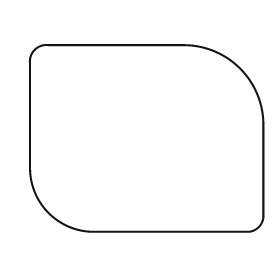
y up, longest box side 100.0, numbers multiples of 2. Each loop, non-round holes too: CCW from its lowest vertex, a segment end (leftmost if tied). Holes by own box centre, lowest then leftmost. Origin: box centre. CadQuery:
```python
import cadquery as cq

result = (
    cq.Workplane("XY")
    .moveTo(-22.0, -40.0)
    .lineTo(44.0, -40.0)
    .threePointArc((48.0, -38.0), (50.0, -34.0))
    .lineTo(50.0, 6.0)
    .threePointArc((40.0, 30.0), (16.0, 40.0))
    .lineTo(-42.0, 40.0)
    .threePointArc((-48.0, 38.0), (-50.0, 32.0))
    .lineTo(-50.0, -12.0)
    .threePointArc((-42.0, -32.0), (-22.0, -40.0))
    .close()
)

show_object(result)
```